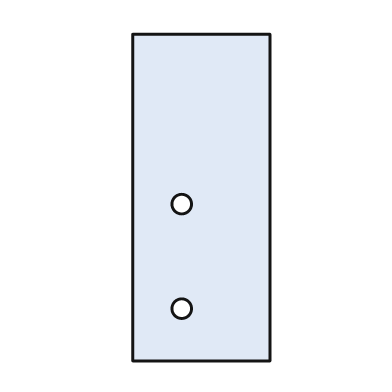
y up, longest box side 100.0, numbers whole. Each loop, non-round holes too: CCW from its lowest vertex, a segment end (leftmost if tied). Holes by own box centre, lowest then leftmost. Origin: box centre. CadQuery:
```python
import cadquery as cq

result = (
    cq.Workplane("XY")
    .moveTo(-21.0, -50.0)
    .lineTo(21.0, -50.0)
    .lineTo(21.0, 50.0)
    .lineTo(-21.0, 50.0)
    .close()
    .moveTo(-6.0, -34.0)
    .circle(3.0)
    .moveTo(-6.0, -2.0)
    .circle(3.0)
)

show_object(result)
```